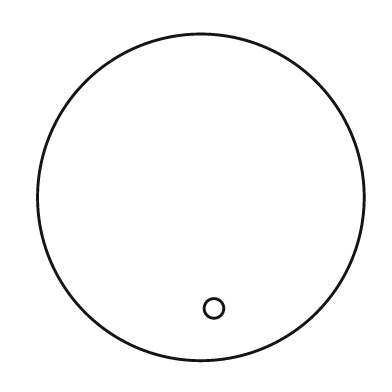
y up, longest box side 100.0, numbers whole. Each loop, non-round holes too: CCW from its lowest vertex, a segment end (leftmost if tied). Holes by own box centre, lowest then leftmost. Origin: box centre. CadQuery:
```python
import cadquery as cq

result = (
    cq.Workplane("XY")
    .moveTo(0.0, 0.0)
    .circle(50.0)
    .moveTo(4.0, -34.0)
    .circle(3.0)
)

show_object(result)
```